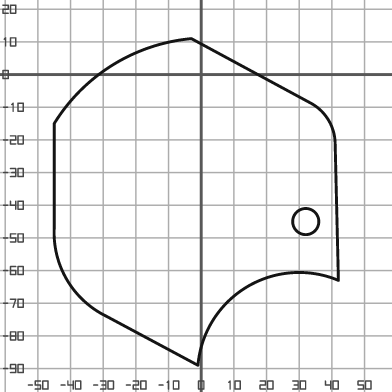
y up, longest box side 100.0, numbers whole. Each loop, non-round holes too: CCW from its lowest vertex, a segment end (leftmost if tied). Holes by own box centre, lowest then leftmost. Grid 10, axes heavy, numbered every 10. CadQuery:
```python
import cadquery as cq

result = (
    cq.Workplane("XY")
    .moveTo(-1.0, -89.0)
    .threePointArc((14.0, -65.0), (42.0, -63.0))
    .lineTo(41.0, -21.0)
    .threePointArc((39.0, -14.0), (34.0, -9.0))
    .lineTo(-3.0, 11.0)
    .threePointArc((-27.0, 3.0), (-45.0, -15.0))
    .lineTo(-45.0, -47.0)
    .threePointArc((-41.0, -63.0), (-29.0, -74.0))
    .close()
    .moveTo(32.0, -45.0)
    .circle(4.0)
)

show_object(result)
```